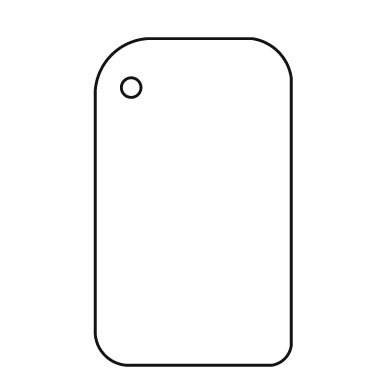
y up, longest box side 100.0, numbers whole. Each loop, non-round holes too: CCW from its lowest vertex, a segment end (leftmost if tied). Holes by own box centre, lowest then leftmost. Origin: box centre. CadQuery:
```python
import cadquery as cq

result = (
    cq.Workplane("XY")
    .moveTo(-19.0, -50.0)
    .lineTo(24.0, -50.0)
    .threePointArc((28.0, -48.0), (30.0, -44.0))
    .lineTo(30.0, 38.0)
    .threePointArc((26.0, 46.0), (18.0, 50.0))
    .lineTo(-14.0, 50.0)
    .threePointArc((-25.0, 45.0), (-30.0, 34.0))
    .lineTo(-30.0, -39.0)
    .threePointArc((-27.0, -47.0), (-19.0, -50.0))
    .close()
    .moveTo(-19.0, 35.0)
    .circle(3.0)
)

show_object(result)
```